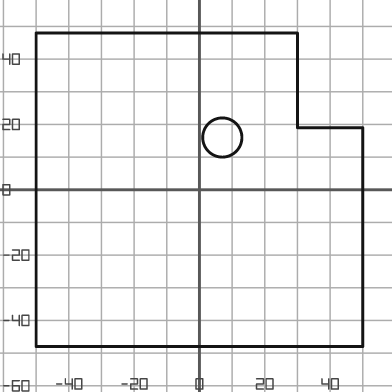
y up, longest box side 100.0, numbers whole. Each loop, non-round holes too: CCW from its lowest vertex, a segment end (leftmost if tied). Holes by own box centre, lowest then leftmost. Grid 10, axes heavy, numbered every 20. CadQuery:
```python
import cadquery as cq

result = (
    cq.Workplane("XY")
    .moveTo(-50.0, -48.0)
    .lineTo(50.0, -48.0)
    .lineTo(50.0, 19.0)
    .lineTo(30.0, 19.0)
    .lineTo(30.0, 48.0)
    .lineTo(-50.0, 48.0)
    .close()
    .moveTo(7.0, 16.0)
    .circle(6.0)
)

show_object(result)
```